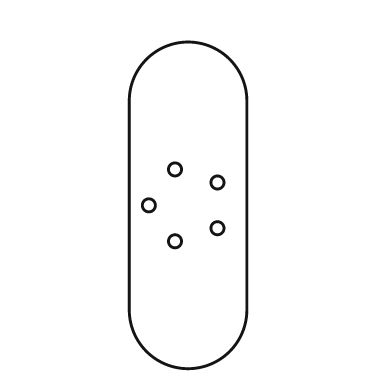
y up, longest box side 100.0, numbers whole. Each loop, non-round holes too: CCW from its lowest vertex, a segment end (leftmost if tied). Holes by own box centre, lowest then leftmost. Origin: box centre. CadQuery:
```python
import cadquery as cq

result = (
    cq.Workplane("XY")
    .moveTo(-18.0, -32.0)
    .threePointArc((0.0, -50.0), (18.0, -32.0))
    .lineTo(18.0, 32.0)
    .threePointArc((0.0, 50.0), (-18.0, 32.0))
    .close()
    .moveTo(-4.0, -11.0)
    .circle(2.0)
    .moveTo(9.0, -7.0)
    .circle(2.0)
    .moveTo(-12.0, 0.0)
    .circle(2.0)
    .moveTo(9.0, 7.0)
    .circle(2.0)
    .moveTo(-4.0, 11.0)
    .circle(2.0)
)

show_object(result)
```